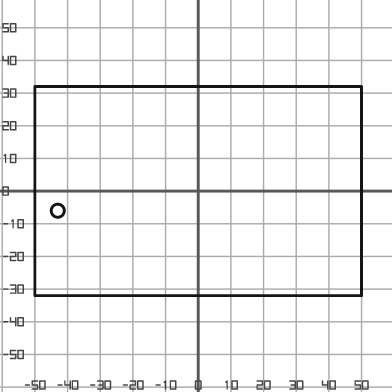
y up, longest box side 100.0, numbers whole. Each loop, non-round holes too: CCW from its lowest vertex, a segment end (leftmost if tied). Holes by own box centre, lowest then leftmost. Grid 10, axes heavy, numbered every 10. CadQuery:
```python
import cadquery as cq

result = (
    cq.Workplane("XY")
    .moveTo(-50.0, -32.0)
    .lineTo(50.0, -32.0)
    .lineTo(50.0, 32.0)
    .lineTo(-50.0, 32.0)
    .close()
    .moveTo(-43.0, -6.0)
    .circle(2.0)
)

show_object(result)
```